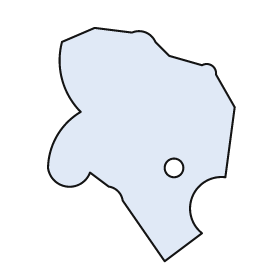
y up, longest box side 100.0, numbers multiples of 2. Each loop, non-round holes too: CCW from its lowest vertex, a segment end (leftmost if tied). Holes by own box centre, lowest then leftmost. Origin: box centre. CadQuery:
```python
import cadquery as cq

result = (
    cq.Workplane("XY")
    .moveTo(10.0, -50.0)
    .lineTo(26.0, -38.0)
    .threePointArc((22.0, -22.0), (36.0, -14.0))
    .lineTo(40.0, 16.0)
    .lineTo(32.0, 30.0)
    .threePointArc((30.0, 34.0), (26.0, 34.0))
    .lineTo(12.0, 38.0)
    .lineTo(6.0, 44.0)
    .threePointArc((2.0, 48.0), (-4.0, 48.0))
    .lineTo(-20.0, 50.0)
    .lineTo(-34.0, 44.0)
    .threePointArc((-34.0, 28.0), (-26.0, 14.0))
    .threePointArc((-36.0, 4.0), (-40.0, -10.0))
    .threePointArc((-32.0, -18.0), (-22.0, -12.0))
    .lineTo(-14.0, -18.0)
    .threePointArc((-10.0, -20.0), (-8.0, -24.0))
    .close()
    .moveTo(14.0, -10.0)
    .circle(4.0)
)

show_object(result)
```